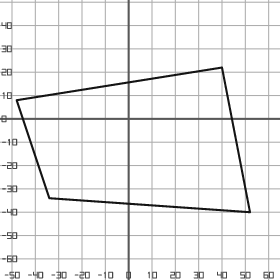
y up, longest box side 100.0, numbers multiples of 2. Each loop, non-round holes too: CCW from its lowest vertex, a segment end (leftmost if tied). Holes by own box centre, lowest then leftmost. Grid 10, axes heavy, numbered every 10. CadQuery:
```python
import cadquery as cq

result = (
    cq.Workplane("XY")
    .moveTo(52.0, -40.0)
    .lineTo(40.0, 22.0)
    .lineTo(-48.0, 8.0)
    .lineTo(-34.0, -34.0)
    .close()
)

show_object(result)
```